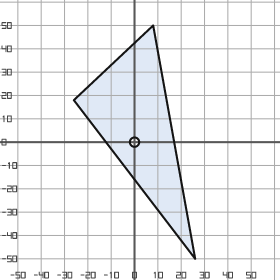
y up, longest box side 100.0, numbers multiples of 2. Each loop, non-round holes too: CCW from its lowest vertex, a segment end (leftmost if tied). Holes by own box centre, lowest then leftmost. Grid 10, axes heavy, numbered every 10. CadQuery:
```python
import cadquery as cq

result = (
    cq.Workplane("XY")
    .moveTo(26.0, -50.0)
    .lineTo(8.0, 50.0)
    .lineTo(-26.0, 18.0)
    .close()
    .moveTo(0.0, 0.0)
    .circle(2.0)
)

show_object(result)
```